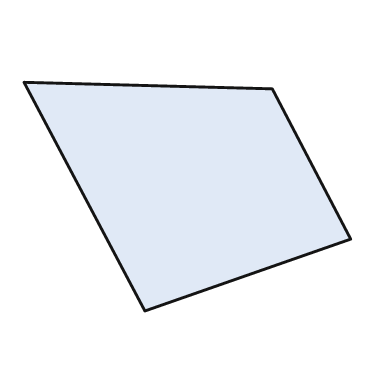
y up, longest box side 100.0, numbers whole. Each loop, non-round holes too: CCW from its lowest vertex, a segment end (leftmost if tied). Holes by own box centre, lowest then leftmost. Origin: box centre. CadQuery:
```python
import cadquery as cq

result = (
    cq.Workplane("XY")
    .moveTo(-13.0, -35.0)
    .lineTo(50.0, -13.0)
    .lineTo(26.0, 33.0)
    .lineTo(-50.0, 35.0)
    .close()
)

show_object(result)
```